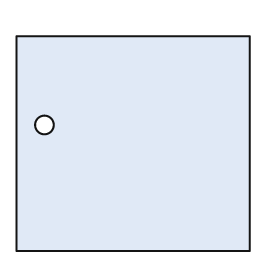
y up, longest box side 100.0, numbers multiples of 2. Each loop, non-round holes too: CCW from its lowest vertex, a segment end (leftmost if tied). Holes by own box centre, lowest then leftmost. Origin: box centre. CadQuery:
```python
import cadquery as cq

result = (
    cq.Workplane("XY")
    .moveTo(-50.0, -46.0)
    .lineTo(50.0, -46.0)
    .lineTo(50.0, 46.0)
    .lineTo(-50.0, 46.0)
    .close()
    .moveTo(-38.0, 8.0)
    .circle(4.0)
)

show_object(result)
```